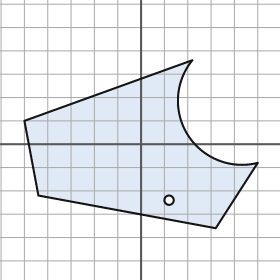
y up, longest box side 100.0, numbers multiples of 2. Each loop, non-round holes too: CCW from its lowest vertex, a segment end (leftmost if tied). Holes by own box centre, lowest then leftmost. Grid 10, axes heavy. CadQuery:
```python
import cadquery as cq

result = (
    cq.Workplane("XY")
    .moveTo(32.0, -36.0)
    .lineTo(50.0, -8.0)
    .threePointArc((20.0, 4.0), (22.0, 36.0))
    .lineTo(-50.0, 10.0)
    .lineTo(-44.0, -22.0)
    .close()
    .moveTo(12.0, -24.0)
    .circle(2.0)
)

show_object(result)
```